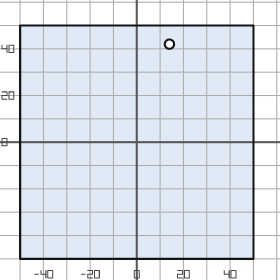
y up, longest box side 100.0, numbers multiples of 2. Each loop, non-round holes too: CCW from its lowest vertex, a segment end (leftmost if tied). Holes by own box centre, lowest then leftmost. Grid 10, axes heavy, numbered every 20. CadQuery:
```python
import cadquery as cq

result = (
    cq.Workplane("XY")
    .moveTo(-50.0, -50.0)
    .lineTo(50.0, -50.0)
    .lineTo(50.0, 50.0)
    .lineTo(-50.0, 50.0)
    .close()
    .moveTo(14.0, 42.0)
    .circle(2.0)
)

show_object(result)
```